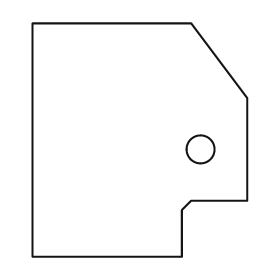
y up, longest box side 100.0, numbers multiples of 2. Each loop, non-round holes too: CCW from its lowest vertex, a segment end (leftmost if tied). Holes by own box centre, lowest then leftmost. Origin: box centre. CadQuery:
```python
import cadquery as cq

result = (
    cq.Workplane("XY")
    .moveTo(-46.0, -50.0)
    .lineTo(18.0, -50.0)
    .lineTo(18.0, -30.0)
    .lineTo(22.0, -26.0)
    .lineTo(46.0, -26.0)
    .lineTo(46.0, 18.0)
    .lineTo(22.0, 50.0)
    .lineTo(-46.0, 50.0)
    .close()
    .moveTo(26.0, -4.0)
    .circle(6.0)
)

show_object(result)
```